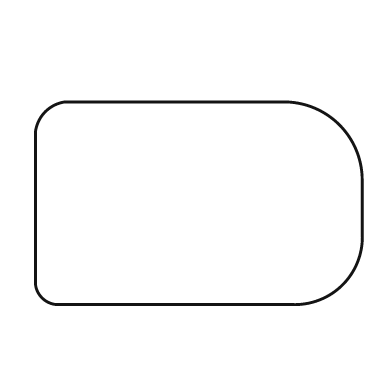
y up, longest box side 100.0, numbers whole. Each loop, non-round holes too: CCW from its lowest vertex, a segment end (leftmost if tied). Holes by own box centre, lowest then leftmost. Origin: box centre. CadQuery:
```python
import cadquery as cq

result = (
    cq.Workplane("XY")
    .moveTo(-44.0, -31.0)
    .lineTo(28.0, -31.0)
    .threePointArc((44.0, -25.0), (50.0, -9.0))
    .lineTo(50.0, 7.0)
    .threePointArc((43.0, 24.0), (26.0, 31.0))
    .lineTo(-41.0, 31.0)
    .threePointArc((-47.0, 28.0), (-50.0, 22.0))
    .lineTo(-50.0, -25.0)
    .threePointArc((-48.0, -29.0), (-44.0, -31.0))
    .close()
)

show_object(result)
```